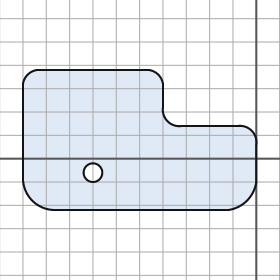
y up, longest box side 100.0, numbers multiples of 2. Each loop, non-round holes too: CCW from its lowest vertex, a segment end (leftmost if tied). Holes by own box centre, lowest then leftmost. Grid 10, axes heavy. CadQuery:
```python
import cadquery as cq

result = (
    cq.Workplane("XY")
    .moveTo(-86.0, -22.0)
    .lineTo(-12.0, -22.0)
    .threePointArc((-4.0, -18.0), (0.0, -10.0))
    .lineTo(0.0, 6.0)
    .threePointArc((-2.0, 12.0), (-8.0, 14.0))
    .lineTo(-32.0, 14.0)
    .threePointArc((-38.0, 16.0), (-40.0, 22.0))
    .lineTo(-40.0, 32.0)
    .threePointArc((-42.0, 36.0), (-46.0, 38.0))
    .lineTo(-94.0, 38.0)
    .threePointArc((-98.0, 36.0), (-100.0, 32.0))
    .lineTo(-100.0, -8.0)
    .threePointArc((-96.0, -18.0), (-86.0, -22.0))
    .close()
    .moveTo(-70.0, -6.0)
    .circle(4.0)
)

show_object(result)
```